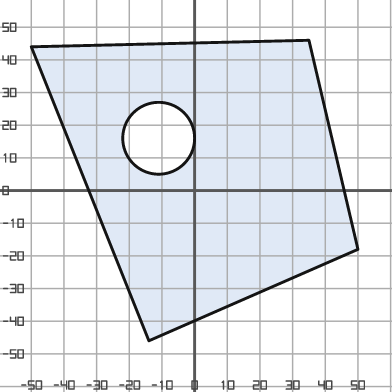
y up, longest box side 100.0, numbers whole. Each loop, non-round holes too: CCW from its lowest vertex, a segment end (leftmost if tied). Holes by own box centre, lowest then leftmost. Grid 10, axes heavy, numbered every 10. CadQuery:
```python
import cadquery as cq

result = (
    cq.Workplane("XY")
    .moveTo(-14.0, -46.0)
    .lineTo(50.0, -18.0)
    .lineTo(35.0, 46.0)
    .lineTo(-50.0, 44.0)
    .close()
    .moveTo(-11.0, 16.0)
    .circle(11.0)
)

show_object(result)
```